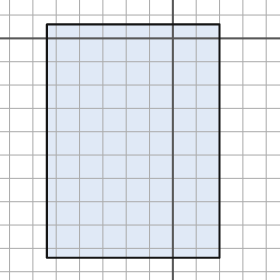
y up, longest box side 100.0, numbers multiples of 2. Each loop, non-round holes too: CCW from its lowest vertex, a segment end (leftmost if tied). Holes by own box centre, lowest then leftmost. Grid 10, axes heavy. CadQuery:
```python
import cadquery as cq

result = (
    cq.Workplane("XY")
    .moveTo(-54.0, -94.0)
    .lineTo(20.0, -94.0)
    .lineTo(20.0, 6.0)
    .lineTo(-54.0, 6.0)
    .close()
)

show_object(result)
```